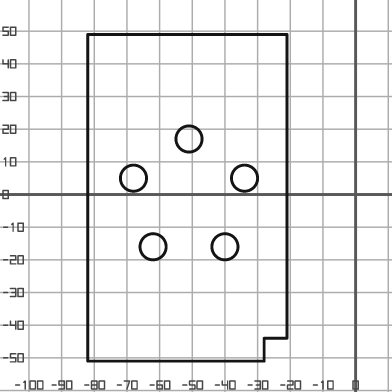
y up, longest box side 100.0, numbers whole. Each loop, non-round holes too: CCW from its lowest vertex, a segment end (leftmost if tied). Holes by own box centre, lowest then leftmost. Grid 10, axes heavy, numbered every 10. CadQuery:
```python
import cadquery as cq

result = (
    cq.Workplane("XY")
    .moveTo(-82.0, -51.0)
    .lineTo(-28.0, -51.0)
    .lineTo(-28.0, -44.0)
    .lineTo(-21.0, -44.0)
    .lineTo(-21.0, 49.0)
    .lineTo(-82.0, 49.0)
    .close()
    .moveTo(-62.0, -16.0)
    .circle(4.0)
    .moveTo(-40.0, -16.0)
    .circle(4.0)
    .moveTo(-68.0, 5.0)
    .circle(4.0)
    .moveTo(-34.0, 5.0)
    .circle(4.0)
    .moveTo(-51.0, 17.0)
    .circle(4.0)
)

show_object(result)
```